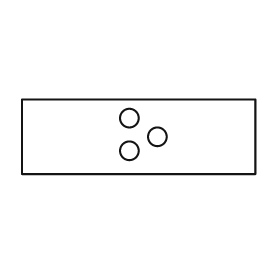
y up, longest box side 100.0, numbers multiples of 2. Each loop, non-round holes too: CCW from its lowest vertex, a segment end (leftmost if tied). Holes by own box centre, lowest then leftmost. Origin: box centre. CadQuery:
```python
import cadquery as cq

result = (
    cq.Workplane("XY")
    .moveTo(-50.0, -16.0)
    .lineTo(50.0, -16.0)
    .lineTo(50.0, 16.0)
    .lineTo(-50.0, 16.0)
    .close()
    .moveTo(-4.0, -6.0)
    .circle(4.0)
    .moveTo(8.0, 0.0)
    .circle(4.0)
    .moveTo(-4.0, 8.0)
    .circle(4.0)
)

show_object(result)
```